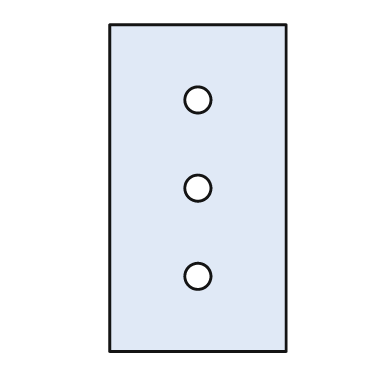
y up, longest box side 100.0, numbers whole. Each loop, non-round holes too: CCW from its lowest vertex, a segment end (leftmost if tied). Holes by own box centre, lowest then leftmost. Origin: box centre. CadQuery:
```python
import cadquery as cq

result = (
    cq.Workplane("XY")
    .moveTo(-27.0, -50.0)
    .lineTo(27.0, -50.0)
    .lineTo(27.0, 50.0)
    .lineTo(-27.0, 50.0)
    .close()
    .moveTo(0.0, -27.0)
    .circle(4.0)
    .moveTo(0.0, 0.0)
    .circle(4.0)
    .moveTo(0.0, 27.0)
    .circle(4.0)
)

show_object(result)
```